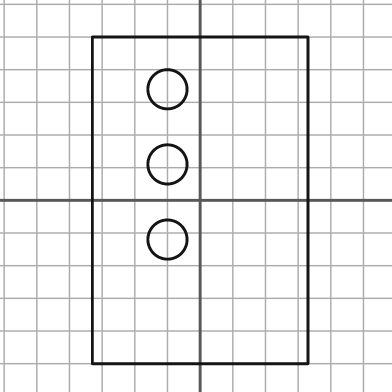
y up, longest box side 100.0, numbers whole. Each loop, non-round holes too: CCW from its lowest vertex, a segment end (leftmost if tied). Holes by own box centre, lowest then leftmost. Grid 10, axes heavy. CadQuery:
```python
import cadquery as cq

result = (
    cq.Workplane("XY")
    .moveTo(-33.0, -50.0)
    .lineTo(33.0, -50.0)
    .lineTo(33.0, 50.0)
    .lineTo(-33.0, 50.0)
    .close()
    .moveTo(-10.0, -12.0)
    .circle(6.0)
    .moveTo(-10.0, 11.0)
    .circle(6.0)
    .moveTo(-10.0, 34.0)
    .circle(6.0)
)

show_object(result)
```